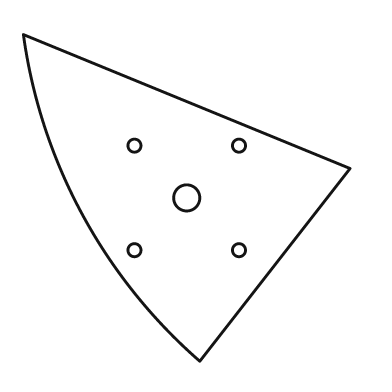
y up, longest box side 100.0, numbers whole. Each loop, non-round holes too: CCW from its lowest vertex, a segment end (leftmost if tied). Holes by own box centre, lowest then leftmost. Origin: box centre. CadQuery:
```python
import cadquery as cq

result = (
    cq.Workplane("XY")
    .moveTo(4.0, -50.0)
    .lineTo(50.0, 9.0)
    .lineTo(-50.0, 50.0)
    .threePointArc((-32.0, -5.0), (4.0, -50.0))
    .close()
    .moveTo(-16.0, -16.0)
    .circle(2.0)
    .moveTo(16.0, -16.0)
    .circle(2.0)
    .moveTo(0.0, 0.0)
    .circle(4.0)
    .moveTo(-16.0, 16.0)
    .circle(2.0)
    .moveTo(16.0, 16.0)
    .circle(2.0)
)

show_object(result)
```